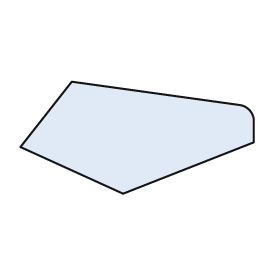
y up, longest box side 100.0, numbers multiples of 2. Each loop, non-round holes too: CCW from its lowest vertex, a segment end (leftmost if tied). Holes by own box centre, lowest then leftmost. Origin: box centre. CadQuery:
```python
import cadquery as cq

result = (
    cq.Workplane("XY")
    .moveTo(-6.0, -24.0)
    .lineTo(50.0, -2.0)
    .lineTo(50.0, 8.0)
    .threePointArc((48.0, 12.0), (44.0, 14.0))
    .lineTo(-28.0, 24.0)
    .lineTo(-50.0, -4.0)
    .close()
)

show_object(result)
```